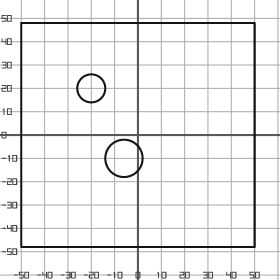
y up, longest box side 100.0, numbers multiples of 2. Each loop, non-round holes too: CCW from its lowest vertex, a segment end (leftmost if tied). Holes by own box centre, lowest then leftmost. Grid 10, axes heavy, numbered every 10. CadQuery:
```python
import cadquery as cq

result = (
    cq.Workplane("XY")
    .moveTo(-50.0, -48.0)
    .lineTo(50.0, -48.0)
    .lineTo(50.0, 48.0)
    .lineTo(-50.0, 48.0)
    .close()
    .moveTo(-6.0, -10.0)
    .circle(8.0)
    .moveTo(-20.0, 20.0)
    .circle(6.0)
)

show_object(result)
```